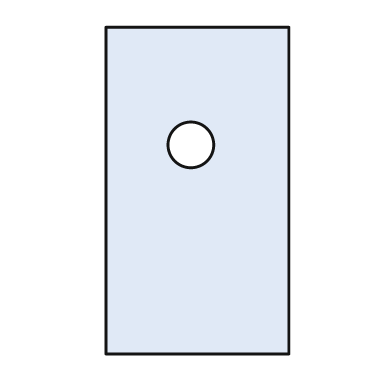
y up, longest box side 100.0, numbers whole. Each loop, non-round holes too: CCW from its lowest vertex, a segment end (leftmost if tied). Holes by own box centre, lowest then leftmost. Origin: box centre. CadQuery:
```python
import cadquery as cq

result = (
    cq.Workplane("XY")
    .moveTo(-28.0, -50.0)
    .lineTo(28.0, -50.0)
    .lineTo(28.0, 50.0)
    .lineTo(-28.0, 50.0)
    .close()
    .moveTo(-2.0, 14.0)
    .circle(7.0)
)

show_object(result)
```